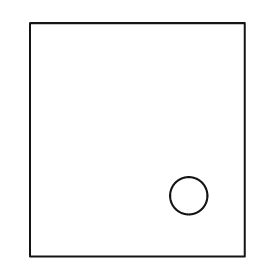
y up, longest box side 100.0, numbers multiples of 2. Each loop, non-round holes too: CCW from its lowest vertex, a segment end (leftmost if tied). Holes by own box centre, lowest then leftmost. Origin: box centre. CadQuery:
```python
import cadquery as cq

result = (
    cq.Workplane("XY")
    .moveTo(-46.0, -50.0)
    .lineTo(46.0, -50.0)
    .lineTo(46.0, 50.0)
    .lineTo(-46.0, 50.0)
    .close()
    .moveTo(22.0, -24.0)
    .circle(8.0)
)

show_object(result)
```